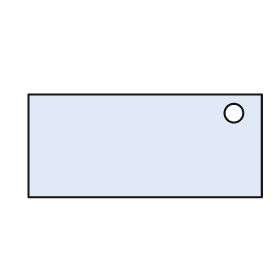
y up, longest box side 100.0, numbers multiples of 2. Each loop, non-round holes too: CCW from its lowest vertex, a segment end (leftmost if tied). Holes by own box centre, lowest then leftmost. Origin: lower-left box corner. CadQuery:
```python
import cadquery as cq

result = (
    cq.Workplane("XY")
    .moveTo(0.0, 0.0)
    .lineTo(100.0, 0.0)
    .lineTo(100.0, 44.0)
    .lineTo(0.0, 44.0)
    .close()
    .moveTo(88.0, 36.0)
    .circle(4.0)
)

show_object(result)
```